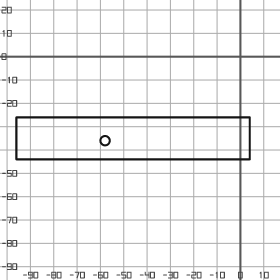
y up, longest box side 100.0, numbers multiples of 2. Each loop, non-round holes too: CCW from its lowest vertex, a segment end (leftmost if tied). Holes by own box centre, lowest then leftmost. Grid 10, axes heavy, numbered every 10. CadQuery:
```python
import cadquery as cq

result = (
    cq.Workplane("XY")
    .moveTo(-96.0, -44.0)
    .lineTo(4.0, -44.0)
    .lineTo(4.0, -26.0)
    .lineTo(-96.0, -26.0)
    .close()
    .moveTo(-58.0, -36.0)
    .circle(2.0)
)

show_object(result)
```